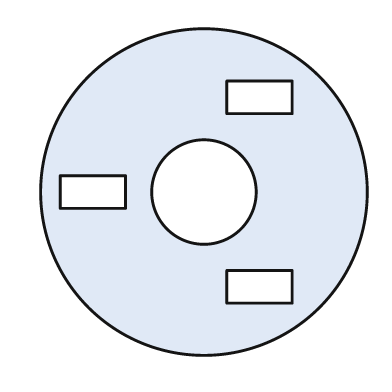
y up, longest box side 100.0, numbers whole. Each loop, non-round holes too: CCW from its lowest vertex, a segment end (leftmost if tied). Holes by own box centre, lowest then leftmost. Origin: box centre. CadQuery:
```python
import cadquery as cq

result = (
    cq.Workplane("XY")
    .moveTo(0.0, 0.0)
    .circle(50.0)
    .moveTo(7.0, -34.0)
    .lineTo(27.0, -34.0)
    .lineTo(27.0, -24.0)
    .lineTo(7.0, -24.0)
    .close()
    .moveTo(-44.0, -5.0)
    .lineTo(-24.0, -5.0)
    .lineTo(-24.0, 5.0)
    .lineTo(-44.0, 5.0)
    .close()
    .moveTo(0.0, 0.0)
    .circle(16.0)
    .moveTo(7.0, 24.0)
    .lineTo(27.0, 24.0)
    .lineTo(27.0, 34.0)
    .lineTo(7.0, 34.0)
    .close()
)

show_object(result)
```